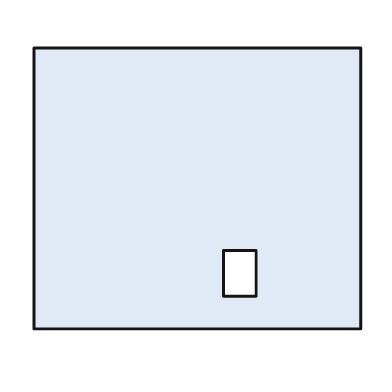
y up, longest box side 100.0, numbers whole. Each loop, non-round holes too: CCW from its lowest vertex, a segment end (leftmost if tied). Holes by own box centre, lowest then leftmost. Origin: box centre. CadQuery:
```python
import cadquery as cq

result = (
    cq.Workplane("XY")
    .moveTo(-50.0, -43.0)
    .lineTo(50.0, -43.0)
    .lineTo(50.0, 43.0)
    .lineTo(-50.0, 43.0)
    .close()
    .moveTo(8.0, -33.0)
    .lineTo(18.0, -33.0)
    .lineTo(18.0, -19.0)
    .lineTo(8.0, -19.0)
    .close()
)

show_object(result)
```